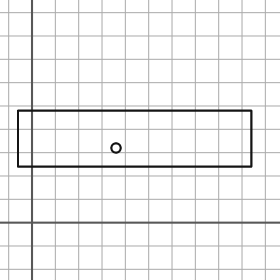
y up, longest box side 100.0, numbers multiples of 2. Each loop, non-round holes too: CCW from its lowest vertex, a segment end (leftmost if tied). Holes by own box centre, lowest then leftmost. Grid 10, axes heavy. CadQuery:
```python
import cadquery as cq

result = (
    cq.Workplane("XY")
    .moveTo(-6.0, 24.0)
    .lineTo(94.0, 24.0)
    .lineTo(94.0, 48.0)
    .lineTo(-6.0, 48.0)
    .close()
    .moveTo(36.0, 32.0)
    .circle(2.0)
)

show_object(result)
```